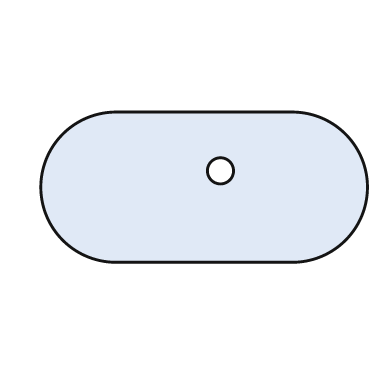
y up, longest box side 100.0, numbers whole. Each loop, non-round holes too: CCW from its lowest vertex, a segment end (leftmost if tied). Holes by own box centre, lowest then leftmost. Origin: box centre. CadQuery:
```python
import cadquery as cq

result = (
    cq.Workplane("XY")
    .moveTo(-27.0, -23.0)
    .lineTo(27.0, -23.0)
    .threePointArc((50.0, 0.0), (27.0, 23.0))
    .lineTo(-27.0, 23.0)
    .threePointArc((-50.0, 0.0), (-27.0, -23.0))
    .close()
    .moveTo(5.0, 5.0)
    .circle(4.0)
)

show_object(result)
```